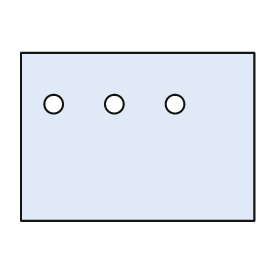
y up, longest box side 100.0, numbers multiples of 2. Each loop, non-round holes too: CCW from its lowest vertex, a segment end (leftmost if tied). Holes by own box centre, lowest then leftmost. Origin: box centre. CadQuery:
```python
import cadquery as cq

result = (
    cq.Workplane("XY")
    .moveTo(-50.0, -36.0)
    .lineTo(50.0, -36.0)
    .lineTo(50.0, 36.0)
    .lineTo(-50.0, 36.0)
    .close()
    .moveTo(-36.0, 14.0)
    .circle(4.0)
    .moveTo(-10.0, 14.0)
    .circle(4.0)
    .moveTo(16.0, 14.0)
    .circle(4.0)
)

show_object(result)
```